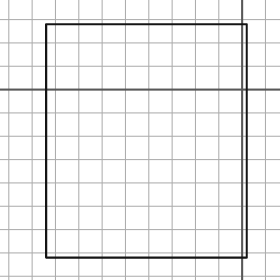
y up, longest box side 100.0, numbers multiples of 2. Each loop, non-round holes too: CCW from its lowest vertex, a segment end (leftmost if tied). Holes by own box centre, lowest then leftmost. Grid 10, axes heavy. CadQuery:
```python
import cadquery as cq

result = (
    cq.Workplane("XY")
    .moveTo(-84.0, -72.0)
    .lineTo(2.0, -72.0)
    .lineTo(2.0, 28.0)
    .lineTo(-84.0, 28.0)
    .close()
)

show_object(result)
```